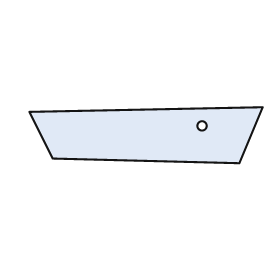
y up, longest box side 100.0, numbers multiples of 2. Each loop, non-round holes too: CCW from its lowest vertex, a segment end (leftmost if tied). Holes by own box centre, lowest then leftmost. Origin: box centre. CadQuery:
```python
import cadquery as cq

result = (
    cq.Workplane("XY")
    .moveTo(40.0, -12.0)
    .lineTo(50.0, 12.0)
    .lineTo(-50.0, 10.0)
    .lineTo(-40.0, -10.0)
    .close()
    .moveTo(24.0, 4.0)
    .circle(2.0)
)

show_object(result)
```